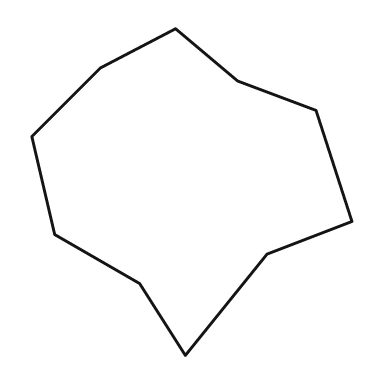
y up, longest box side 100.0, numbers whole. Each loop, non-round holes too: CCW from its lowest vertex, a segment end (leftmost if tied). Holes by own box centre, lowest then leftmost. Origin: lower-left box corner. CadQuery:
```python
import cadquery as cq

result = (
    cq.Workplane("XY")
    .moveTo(47.0, 0.0)
    .lineTo(72.0, 31.0)
    .lineTo(98.0, 41.0)
    .lineTo(87.0, 75.0)
    .lineTo(63.0, 84.0)
    .lineTo(44.0, 100.0)
    .lineTo(21.0, 88.0)
    .lineTo(0.0, 67.0)
    .lineTo(7.0, 37.0)
    .lineTo(33.0, 22.0)
    .close()
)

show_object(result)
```